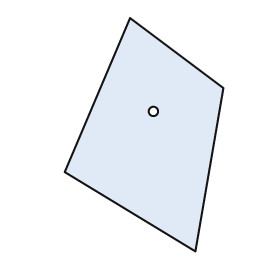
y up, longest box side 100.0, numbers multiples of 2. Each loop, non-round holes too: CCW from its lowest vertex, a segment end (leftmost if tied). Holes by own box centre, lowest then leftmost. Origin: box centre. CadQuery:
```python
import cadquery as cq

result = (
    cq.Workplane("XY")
    .moveTo(22.0, -50.0)
    .lineTo(34.0, 20.0)
    .lineTo(-6.0, 50.0)
    .lineTo(-34.0, -16.0)
    .close()
    .moveTo(4.0, 10.0)
    .circle(2.0)
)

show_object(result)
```